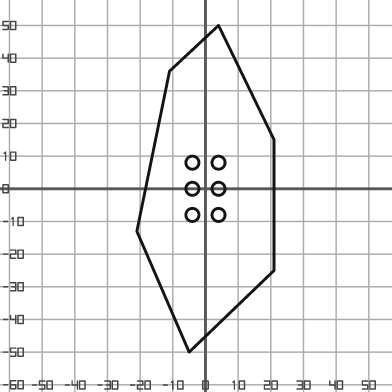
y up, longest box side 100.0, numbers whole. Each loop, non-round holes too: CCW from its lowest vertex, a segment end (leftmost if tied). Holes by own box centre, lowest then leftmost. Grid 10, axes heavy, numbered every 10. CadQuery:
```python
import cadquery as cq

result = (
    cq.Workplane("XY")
    .moveTo(-5.0, -50.0)
    .lineTo(21.0, -25.0)
    .lineTo(21.0, 15.0)
    .lineTo(4.0, 50.0)
    .lineTo(-11.0, 36.0)
    .lineTo(-21.0, -13.0)
    .close()
    .moveTo(-4.0, -8.0)
    .circle(2.0)
    .moveTo(4.0, -8.0)
    .circle(2.0)
    .moveTo(-4.0, 0.0)
    .circle(2.0)
    .moveTo(4.0, 0.0)
    .circle(2.0)
    .moveTo(-4.0, 8.0)
    .circle(2.0)
    .moveTo(4.0, 8.0)
    .circle(2.0)
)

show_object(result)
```